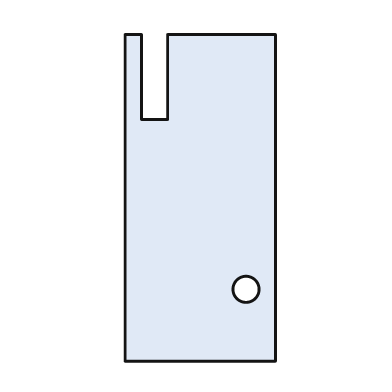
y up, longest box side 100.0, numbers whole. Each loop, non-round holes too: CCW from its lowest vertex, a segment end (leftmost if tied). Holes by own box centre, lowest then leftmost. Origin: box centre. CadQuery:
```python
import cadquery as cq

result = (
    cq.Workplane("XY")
    .moveTo(-23.0, -50.0)
    .lineTo(23.0, -50.0)
    .lineTo(23.0, 50.0)
    .lineTo(-10.0, 50.0)
    .lineTo(-10.0, 24.0)
    .lineTo(-18.0, 24.0)
    .lineTo(-18.0, 50.0)
    .lineTo(-23.0, 50.0)
    .close()
    .moveTo(14.0, -28.0)
    .circle(4.0)
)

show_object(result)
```